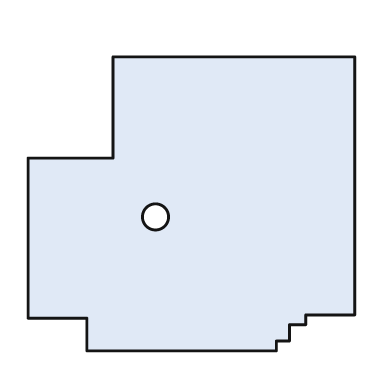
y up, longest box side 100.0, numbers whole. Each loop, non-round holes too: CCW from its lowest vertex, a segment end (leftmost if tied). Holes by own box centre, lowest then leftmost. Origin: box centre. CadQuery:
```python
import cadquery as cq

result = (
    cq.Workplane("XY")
    .moveTo(-32.0, -45.0)
    .lineTo(26.0, -45.0)
    .lineTo(26.0, -42.0)
    .lineTo(30.0, -42.0)
    .lineTo(30.0, -37.0)
    .lineTo(35.0, -37.0)
    .lineTo(35.0, -34.0)
    .lineTo(50.0, -34.0)
    .lineTo(50.0, 45.0)
    .lineTo(-24.0, 45.0)
    .lineTo(-24.0, 14.0)
    .lineTo(-50.0, 14.0)
    .lineTo(-50.0, -35.0)
    .lineTo(-32.0, -35.0)
    .close()
    .moveTo(-11.0, -4.0)
    .circle(4.0)
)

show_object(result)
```